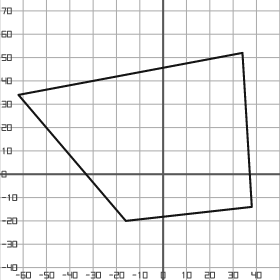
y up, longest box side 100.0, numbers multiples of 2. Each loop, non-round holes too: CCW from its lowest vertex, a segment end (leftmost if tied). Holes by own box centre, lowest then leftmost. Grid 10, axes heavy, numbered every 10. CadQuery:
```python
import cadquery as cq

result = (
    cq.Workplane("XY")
    .moveTo(-16.0, -20.0)
    .lineTo(38.0, -14.0)
    .lineTo(34.0, 52.0)
    .lineTo(-62.0, 34.0)
    .close()
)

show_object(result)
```